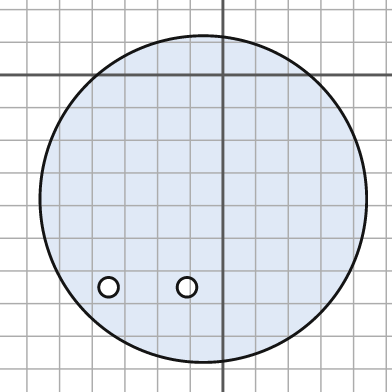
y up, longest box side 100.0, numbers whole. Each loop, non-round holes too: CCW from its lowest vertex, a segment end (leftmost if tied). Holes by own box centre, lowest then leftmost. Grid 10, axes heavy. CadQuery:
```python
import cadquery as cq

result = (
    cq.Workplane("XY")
    .moveTo(-6.0, -38.0)
    .circle(50.0)
    .moveTo(-35.0, -65.0)
    .circle(3.0)
    .moveTo(-11.0, -65.0)
    .circle(3.0)
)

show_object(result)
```